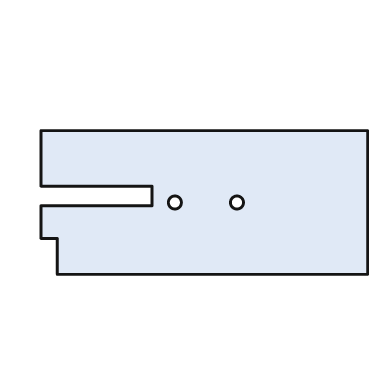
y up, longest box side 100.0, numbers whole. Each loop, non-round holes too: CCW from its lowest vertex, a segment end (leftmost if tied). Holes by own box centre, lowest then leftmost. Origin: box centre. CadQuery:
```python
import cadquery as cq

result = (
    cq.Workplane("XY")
    .moveTo(-45.0, -22.0)
    .lineTo(50.0, -22.0)
    .lineTo(50.0, 22.0)
    .lineTo(-50.0, 22.0)
    .lineTo(-50.0, 5.0)
    .lineTo(-16.0, 5.0)
    .lineTo(-16.0, -1.0)
    .lineTo(-50.0, -1.0)
    .lineTo(-50.0, -11.0)
    .lineTo(-45.0, -11.0)
    .close()
    .moveTo(-9.0, 0.0)
    .circle(2.0)
    .moveTo(10.0, 0.0)
    .circle(2.0)
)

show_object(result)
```